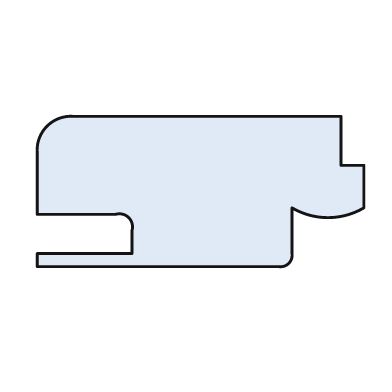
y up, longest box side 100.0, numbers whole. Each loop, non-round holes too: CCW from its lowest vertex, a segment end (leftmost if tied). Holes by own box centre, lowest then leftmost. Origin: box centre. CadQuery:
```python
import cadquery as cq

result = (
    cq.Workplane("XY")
    .moveTo(-50.0, -23.0)
    .lineTo(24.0, -23.0)
    .threePointArc((27.0, -22.0), (28.0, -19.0))
    .lineTo(28.0, -5.0)
    .threePointArc((39.0, -8.0), (50.0, -5.0))
    .lineTo(50.0, 8.0)
    .lineTo(43.0, 8.0)
    .lineTo(43.0, 23.0)
    .lineTo(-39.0, 23.0)
    .threePointArc((-47.0, 20.0), (-50.0, 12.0))
    .lineTo(-50.0, -7.0)
    .lineTo(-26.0, -7.0)
    .threePointArc((-22.0, -8.0), (-21.0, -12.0))
    .lineTo(-21.0, -19.0)
    .lineTo(-50.0, -19.0)
    .close()
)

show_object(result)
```